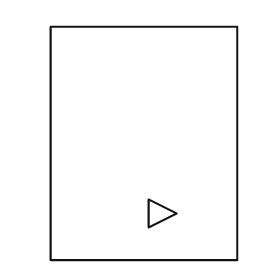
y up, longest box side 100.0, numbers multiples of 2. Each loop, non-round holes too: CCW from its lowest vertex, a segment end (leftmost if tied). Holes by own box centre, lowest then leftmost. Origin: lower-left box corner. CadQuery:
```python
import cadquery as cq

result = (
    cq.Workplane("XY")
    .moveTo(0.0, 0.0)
    .lineTo(80.0, 0.0)
    .lineTo(80.0, 100.0)
    .lineTo(0.0, 100.0)
    .close()
    .moveTo(42.0, 14.0)
    .lineTo(54.0, 20.0)
    .lineTo(42.0, 26.0)
    .close()
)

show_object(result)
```